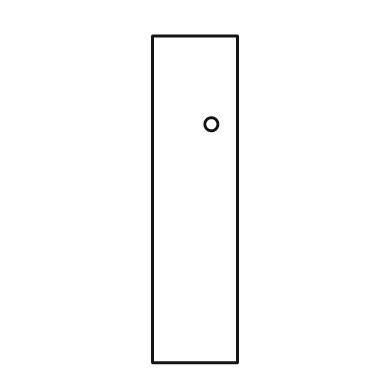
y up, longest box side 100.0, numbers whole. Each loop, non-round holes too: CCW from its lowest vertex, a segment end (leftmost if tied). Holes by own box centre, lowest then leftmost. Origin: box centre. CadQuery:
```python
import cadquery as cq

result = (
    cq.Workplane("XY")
    .moveTo(-13.0, -50.0)
    .lineTo(13.0, -50.0)
    .lineTo(13.0, 50.0)
    .lineTo(-13.0, 50.0)
    .close()
    .moveTo(5.0, 23.0)
    .circle(2.0)
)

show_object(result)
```